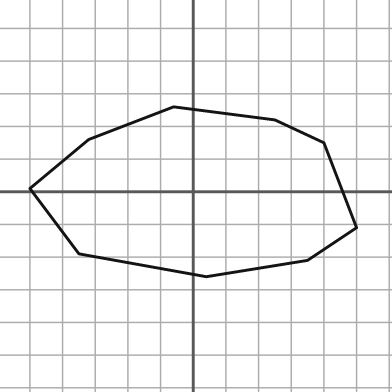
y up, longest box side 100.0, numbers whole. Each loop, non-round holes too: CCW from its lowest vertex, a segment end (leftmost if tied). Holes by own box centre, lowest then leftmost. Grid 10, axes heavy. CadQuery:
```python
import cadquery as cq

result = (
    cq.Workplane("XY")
    .moveTo(4.0, -26.0)
    .lineTo(35.0, -21.0)
    .lineTo(50.0, -11.0)
    .lineTo(40.0, 15.0)
    .lineTo(25.0, 22.0)
    .lineTo(-6.0, 26.0)
    .lineTo(-32.0, 16.0)
    .lineTo(-50.0, 1.0)
    .lineTo(-35.0, -19.0)
    .close()
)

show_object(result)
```